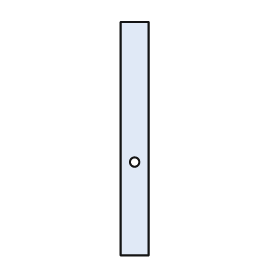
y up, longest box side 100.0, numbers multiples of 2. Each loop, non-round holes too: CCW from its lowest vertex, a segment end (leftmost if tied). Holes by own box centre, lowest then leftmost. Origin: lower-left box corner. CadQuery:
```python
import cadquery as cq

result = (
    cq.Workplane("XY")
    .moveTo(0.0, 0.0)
    .lineTo(12.0, 0.0)
    .lineTo(12.0, 100.0)
    .lineTo(0.0, 100.0)
    .close()
    .moveTo(6.0, 40.0)
    .circle(2.0)
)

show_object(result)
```